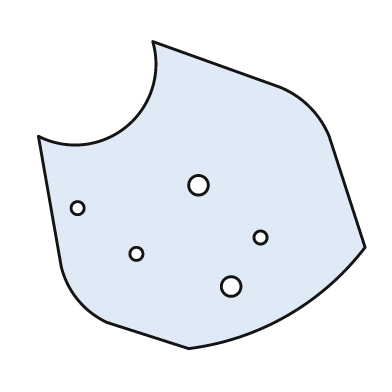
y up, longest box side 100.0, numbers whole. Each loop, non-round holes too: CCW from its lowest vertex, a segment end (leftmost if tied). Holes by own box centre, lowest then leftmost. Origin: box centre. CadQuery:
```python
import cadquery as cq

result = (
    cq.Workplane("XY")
    .moveTo(-4.0, -47.0)
    .threePointArc((26.0, -37.0), (50.0, -16.0))
    .lineTo(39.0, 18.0)
    .threePointArc((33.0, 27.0), (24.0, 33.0))
    .lineTo(-15.0, 47.0)
    .threePointArc((-23.0, 21.0), (-50.0, 18.0))
    .lineTo(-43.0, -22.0)
    .threePointArc((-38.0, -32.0), (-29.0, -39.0))
    .close()
    .moveTo(9.0, -28.0)
    .circle(3.0)
    .moveTo(-20.0, -18.0)
    .circle(2.0)
    .moveTo(18.0, -13.0)
    .circle(2.0)
    .moveTo(-38.0, -4.0)
    .circle(2.0)
    .moveTo(-1.0, 3.0)
    .circle(3.0)
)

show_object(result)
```